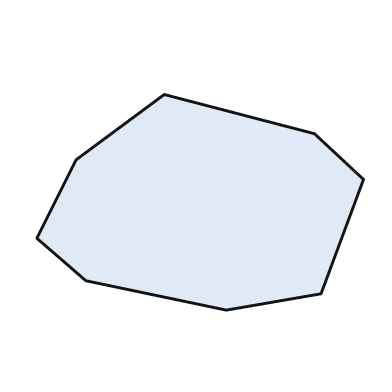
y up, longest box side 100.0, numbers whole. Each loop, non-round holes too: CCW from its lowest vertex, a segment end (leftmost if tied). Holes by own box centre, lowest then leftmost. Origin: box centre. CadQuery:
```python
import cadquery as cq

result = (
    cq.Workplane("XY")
    .moveTo(8.0, -33.0)
    .lineTo(37.0, -28.0)
    .lineTo(50.0, 7.0)
    .lineTo(35.0, 21.0)
    .lineTo(-11.0, 33.0)
    .lineTo(-38.0, 13.0)
    .lineTo(-50.0, -11.0)
    .lineTo(-35.0, -24.0)
    .close()
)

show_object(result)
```